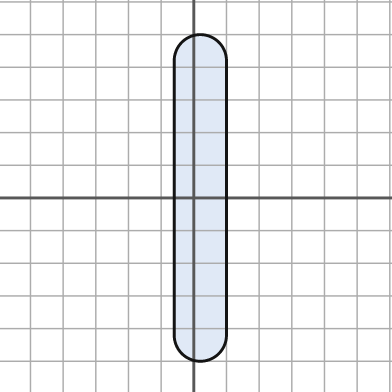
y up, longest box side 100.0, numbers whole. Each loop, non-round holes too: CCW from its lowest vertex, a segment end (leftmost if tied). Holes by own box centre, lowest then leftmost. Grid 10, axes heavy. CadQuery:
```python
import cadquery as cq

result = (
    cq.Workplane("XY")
    .moveTo(-6.0, -42.0)
    .threePointArc((2.0, -50.0), (10.0, -42.0))
    .lineTo(10.0, 42.0)
    .threePointArc((2.0, 50.0), (-6.0, 42.0))
    .close()
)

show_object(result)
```